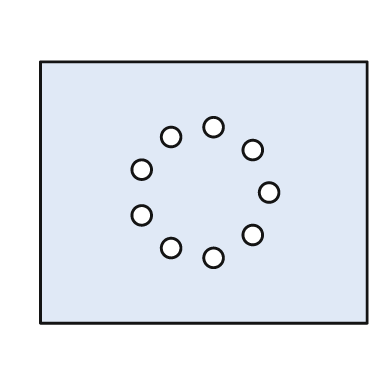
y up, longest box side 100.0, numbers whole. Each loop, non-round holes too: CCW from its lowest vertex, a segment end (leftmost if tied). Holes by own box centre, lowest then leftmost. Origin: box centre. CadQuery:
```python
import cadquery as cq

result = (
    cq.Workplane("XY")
    .moveTo(-50.0, -40.0)
    .lineTo(50.0, -40.0)
    .lineTo(50.0, 40.0)
    .lineTo(-50.0, 40.0)
    .close()
    .moveTo(3.0, -20.0)
    .circle(3.0)
    .moveTo(-10.0, -17.0)
    .circle(3.0)
    .moveTo(15.0, -13.0)
    .circle(3.0)
    .moveTo(-19.0, -7.0)
    .circle(3.0)
    .moveTo(20.0, 0.0)
    .circle(3.0)
    .moveTo(-19.0, 7.0)
    .circle(3.0)
    .moveTo(15.0, 13.0)
    .circle(3.0)
    .moveTo(-10.0, 17.0)
    .circle(3.0)
    .moveTo(3.0, 20.0)
    .circle(3.0)
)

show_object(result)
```